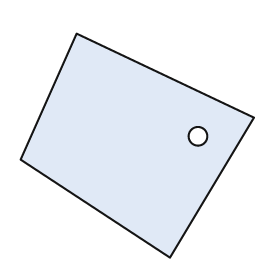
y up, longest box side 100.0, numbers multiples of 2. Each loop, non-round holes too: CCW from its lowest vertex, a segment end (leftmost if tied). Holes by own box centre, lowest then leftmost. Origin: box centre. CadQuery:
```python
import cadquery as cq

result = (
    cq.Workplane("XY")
    .moveTo(14.0, -48.0)
    .lineTo(50.0, 12.0)
    .lineTo(-26.0, 48.0)
    .lineTo(-50.0, -6.0)
    .close()
    .moveTo(26.0, 4.0)
    .circle(4.0)
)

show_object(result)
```